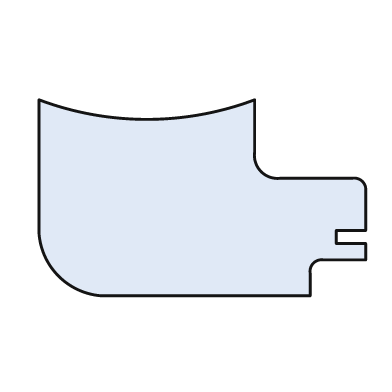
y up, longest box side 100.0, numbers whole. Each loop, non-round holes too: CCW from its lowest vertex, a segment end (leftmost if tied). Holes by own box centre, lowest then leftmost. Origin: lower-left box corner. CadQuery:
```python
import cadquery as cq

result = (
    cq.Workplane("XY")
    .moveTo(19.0, 0.0)
    .lineTo(83.0, 0.0)
    .lineTo(83.0, 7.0)
    .threePointArc((84.0, 10.0), (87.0, 11.0))
    .lineTo(100.0, 11.0)
    .lineTo(100.0, 16.0)
    .lineTo(91.0, 16.0)
    .lineTo(91.0, 20.0)
    .lineTo(100.0, 20.0)
    .lineTo(100.0, 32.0)
    .threePointArc((99.0, 35.0), (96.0, 36.0))
    .lineTo(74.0, 36.0)
    .threePointArc((68.0, 38.0), (66.0, 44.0))
    .lineTo(66.0, 60.0)
    .threePointArc((33.0, 54.0), (0.0, 60.0))
    .lineTo(0.0, 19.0)
    .threePointArc((6.0, 6.0), (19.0, 0.0))
    .close()
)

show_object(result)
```